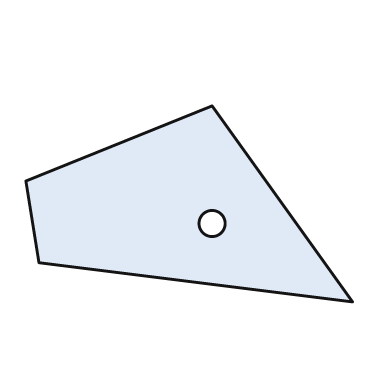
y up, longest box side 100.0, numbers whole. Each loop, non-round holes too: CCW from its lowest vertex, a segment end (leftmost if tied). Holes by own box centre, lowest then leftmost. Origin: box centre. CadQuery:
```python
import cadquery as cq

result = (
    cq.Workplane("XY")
    .moveTo(50.0, -30.0)
    .lineTo(7.0, 30.0)
    .lineTo(-50.0, 7.0)
    .lineTo(-46.0, -18.0)
    .close()
    .moveTo(7.0, -6.0)
    .circle(4.0)
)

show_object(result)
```